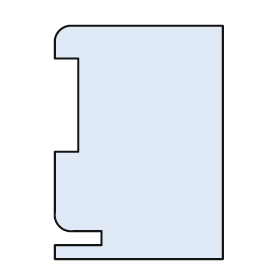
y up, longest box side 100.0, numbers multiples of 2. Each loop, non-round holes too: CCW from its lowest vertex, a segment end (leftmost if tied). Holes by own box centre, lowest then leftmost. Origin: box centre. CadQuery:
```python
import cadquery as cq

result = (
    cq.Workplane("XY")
    .moveTo(-36.0, -50.0)
    .lineTo(36.0, -50.0)
    .lineTo(36.0, 50.0)
    .lineTo(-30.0, 50.0)
    .threePointArc((-34.0, 48.0), (-36.0, 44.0))
    .lineTo(-36.0, 36.0)
    .lineTo(-26.0, 36.0)
    .lineTo(-26.0, -4.0)
    .lineTo(-36.0, -4.0)
    .lineTo(-36.0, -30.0)
    .threePointArc((-34.0, -36.0), (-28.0, -38.0))
    .lineTo(-16.0, -38.0)
    .lineTo(-16.0, -44.0)
    .lineTo(-36.0, -44.0)
    .close()
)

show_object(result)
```